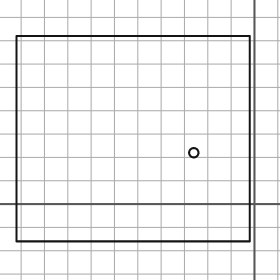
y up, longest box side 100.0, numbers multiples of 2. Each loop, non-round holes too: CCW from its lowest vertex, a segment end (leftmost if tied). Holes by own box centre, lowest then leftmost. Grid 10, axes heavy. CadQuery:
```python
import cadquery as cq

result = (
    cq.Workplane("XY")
    .moveTo(-102.0, -16.0)
    .lineTo(-2.0, -16.0)
    .lineTo(-2.0, 72.0)
    .lineTo(-102.0, 72.0)
    .close()
    .moveTo(-26.0, 22.0)
    .circle(2.0)
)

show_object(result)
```